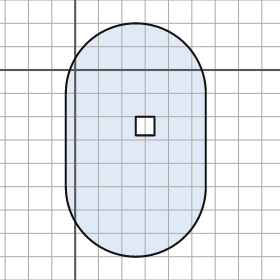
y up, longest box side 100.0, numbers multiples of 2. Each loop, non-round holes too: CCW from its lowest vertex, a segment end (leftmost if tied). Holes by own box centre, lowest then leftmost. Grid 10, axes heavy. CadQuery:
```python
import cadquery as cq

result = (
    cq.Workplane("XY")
    .moveTo(-4.0, -50.0)
    .threePointArc((26.0, -80.0), (56.0, -50.0))
    .lineTo(56.0, -10.0)
    .threePointArc((26.0, 20.0), (-4.0, -10.0))
    .close()
    .moveTo(26.0, -28.0)
    .lineTo(34.0, -28.0)
    .lineTo(34.0, -20.0)
    .lineTo(26.0, -20.0)
    .close()
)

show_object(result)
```